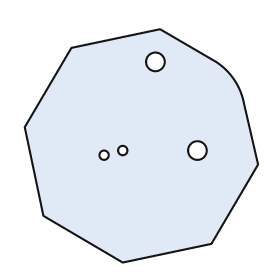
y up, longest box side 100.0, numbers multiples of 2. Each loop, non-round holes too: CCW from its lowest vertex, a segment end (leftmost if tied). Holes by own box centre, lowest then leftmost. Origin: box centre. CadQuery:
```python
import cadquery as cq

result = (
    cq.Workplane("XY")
    .moveTo(-8.0, -50.0)
    .lineTo(30.0, -42.0)
    .lineTo(50.0, -8.0)
    .lineTo(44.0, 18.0)
    .threePointArc((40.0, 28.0), (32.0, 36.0))
    .lineTo(8.0, 50.0)
    .lineTo(-30.0, 42.0)
    .lineTo(-50.0, 8.0)
    .lineTo(-42.0, -30.0)
    .close()
    .moveTo(-16.0, -4.0)
    .circle(2.0)
    .moveTo(-8.0, -2.0)
    .circle(2.0)
    .moveTo(24.0, -2.0)
    .circle(4.0)
    .moveTo(6.0, 36.0)
    .circle(4.0)
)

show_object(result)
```